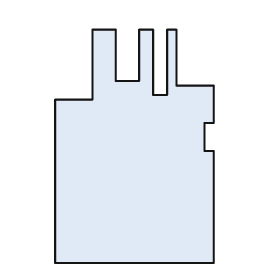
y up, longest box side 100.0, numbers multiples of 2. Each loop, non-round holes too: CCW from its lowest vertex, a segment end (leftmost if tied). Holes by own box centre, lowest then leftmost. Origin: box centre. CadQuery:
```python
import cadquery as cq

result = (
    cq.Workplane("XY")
    .moveTo(-34.0, -50.0)
    .lineTo(34.0, -50.0)
    .lineTo(34.0, -2.0)
    .lineTo(30.0, -2.0)
    .lineTo(30.0, 10.0)
    .lineTo(34.0, 10.0)
    .lineTo(34.0, 26.0)
    .lineTo(18.0, 26.0)
    .lineTo(18.0, 50.0)
    .lineTo(14.0, 50.0)
    .lineTo(14.0, 22.0)
    .lineTo(8.0, 22.0)
    .lineTo(8.0, 50.0)
    .lineTo(2.0, 50.0)
    .lineTo(2.0, 28.0)
    .lineTo(-8.0, 28.0)
    .lineTo(-8.0, 50.0)
    .lineTo(-18.0, 50.0)
    .lineTo(-18.0, 20.0)
    .lineTo(-34.0, 20.0)
    .close()
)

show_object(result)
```